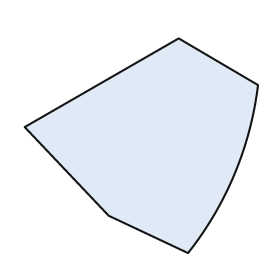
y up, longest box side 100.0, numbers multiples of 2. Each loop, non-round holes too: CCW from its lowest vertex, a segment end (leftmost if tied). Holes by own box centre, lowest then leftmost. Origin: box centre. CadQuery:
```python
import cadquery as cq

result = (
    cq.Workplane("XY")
    .moveTo(20.0, -46.0)
    .threePointArc((40.0, -12.0), (50.0, 26.0))
    .lineTo(16.0, 46.0)
    .lineTo(-50.0, 8.0)
    .lineTo(-14.0, -30.0)
    .close()
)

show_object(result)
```